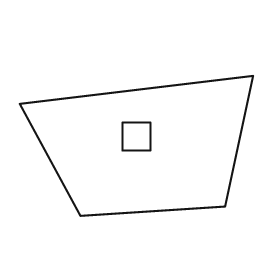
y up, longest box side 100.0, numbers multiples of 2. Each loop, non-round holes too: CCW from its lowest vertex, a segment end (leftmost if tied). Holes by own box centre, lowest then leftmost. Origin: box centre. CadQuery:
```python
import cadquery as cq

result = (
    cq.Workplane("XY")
    .moveTo(-24.0, -30.0)
    .lineTo(38.0, -26.0)
    .lineTo(50.0, 30.0)
    .lineTo(-50.0, 18.0)
    .close()
    .moveTo(-6.0, -2.0)
    .lineTo(6.0, -2.0)
    .lineTo(6.0, 10.0)
    .lineTo(-6.0, 10.0)
    .close()
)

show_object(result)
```